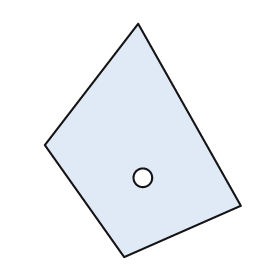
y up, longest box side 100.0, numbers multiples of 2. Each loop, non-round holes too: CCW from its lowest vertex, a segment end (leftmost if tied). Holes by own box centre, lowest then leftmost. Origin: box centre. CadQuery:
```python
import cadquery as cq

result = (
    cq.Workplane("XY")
    .moveTo(-8.0, -50.0)
    .lineTo(42.0, -28.0)
    .lineTo(-2.0, 50.0)
    .lineTo(-42.0, -2.0)
    .close()
    .moveTo(0.0, -16.0)
    .circle(4.0)
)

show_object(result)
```